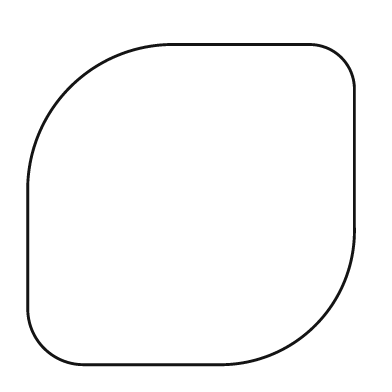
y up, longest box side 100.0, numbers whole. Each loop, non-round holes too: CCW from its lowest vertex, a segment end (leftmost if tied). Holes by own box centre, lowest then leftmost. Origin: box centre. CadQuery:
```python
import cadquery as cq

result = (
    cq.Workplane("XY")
    .moveTo(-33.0, -49.0)
    .lineTo(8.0, -49.0)
    .threePointArc((38.0, -37.0), (50.0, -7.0))
    .lineTo(50.0, 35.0)
    .threePointArc((46.0, 45.0), (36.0, 49.0))
    .lineTo(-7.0, 49.0)
    .threePointArc((-37.0, 36.0), (-50.0, 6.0))
    .lineTo(-50.0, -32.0)
    .threePointArc((-45.0, -44.0), (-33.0, -49.0))
    .close()
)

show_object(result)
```